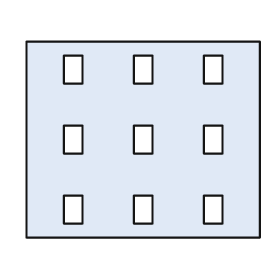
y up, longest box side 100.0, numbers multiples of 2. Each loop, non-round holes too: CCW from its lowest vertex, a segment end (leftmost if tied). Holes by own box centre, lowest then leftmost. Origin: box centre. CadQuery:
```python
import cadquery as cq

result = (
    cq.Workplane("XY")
    .moveTo(-50.0, -42.0)
    .lineTo(50.0, -42.0)
    .lineTo(50.0, 42.0)
    .lineTo(-50.0, 42.0)
    .close()
    .moveTo(-34.0, -36.0)
    .lineTo(-26.0, -36.0)
    .lineTo(-26.0, -24.0)
    .lineTo(-34.0, -24.0)
    .close()
    .moveTo(-4.0, -36.0)
    .lineTo(4.0, -36.0)
    .lineTo(4.0, -24.0)
    .lineTo(-4.0, -24.0)
    .close()
    .moveTo(26.0, -36.0)
    .lineTo(34.0, -36.0)
    .lineTo(34.0, -24.0)
    .lineTo(26.0, -24.0)
    .close()
    .moveTo(-34.0, -6.0)
    .lineTo(-26.0, -6.0)
    .lineTo(-26.0, 6.0)
    .lineTo(-34.0, 6.0)
    .close()
    .moveTo(-4.0, -6.0)
    .lineTo(4.0, -6.0)
    .lineTo(4.0, 6.0)
    .lineTo(-4.0, 6.0)
    .close()
    .moveTo(26.0, -6.0)
    .lineTo(34.0, -6.0)
    .lineTo(34.0, 6.0)
    .lineTo(26.0, 6.0)
    .close()
    .moveTo(-34.0, 24.0)
    .lineTo(-26.0, 24.0)
    .lineTo(-26.0, 36.0)
    .lineTo(-34.0, 36.0)
    .close()
    .moveTo(-4.0, 24.0)
    .lineTo(4.0, 24.0)
    .lineTo(4.0, 36.0)
    .lineTo(-4.0, 36.0)
    .close()
    .moveTo(26.0, 24.0)
    .lineTo(34.0, 24.0)
    .lineTo(34.0, 36.0)
    .lineTo(26.0, 36.0)
    .close()
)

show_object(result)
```